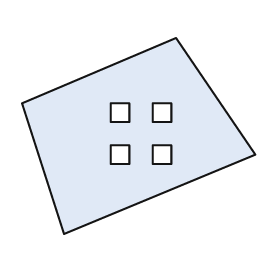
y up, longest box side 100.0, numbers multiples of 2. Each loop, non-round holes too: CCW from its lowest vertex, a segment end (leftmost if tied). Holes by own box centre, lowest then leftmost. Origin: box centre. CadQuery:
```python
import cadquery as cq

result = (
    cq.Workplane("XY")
    .moveTo(-32.0, -42.0)
    .lineTo(50.0, -8.0)
    .lineTo(16.0, 42.0)
    .lineTo(-50.0, 14.0)
    .close()
    .moveTo(-12.0, -12.0)
    .lineTo(-4.0, -12.0)
    .lineTo(-4.0, -4.0)
    .lineTo(-12.0, -4.0)
    .close()
    .moveTo(6.0, -12.0)
    .lineTo(14.0, -12.0)
    .lineTo(14.0, -4.0)
    .lineTo(6.0, -4.0)
    .close()
    .moveTo(-12.0, 6.0)
    .lineTo(-4.0, 6.0)
    .lineTo(-4.0, 14.0)
    .lineTo(-12.0, 14.0)
    .close()
    .moveTo(6.0, 6.0)
    .lineTo(14.0, 6.0)
    .lineTo(14.0, 14.0)
    .lineTo(6.0, 14.0)
    .close()
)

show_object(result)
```